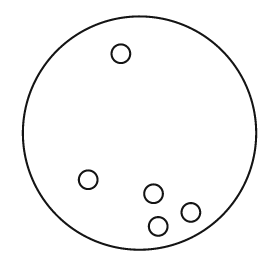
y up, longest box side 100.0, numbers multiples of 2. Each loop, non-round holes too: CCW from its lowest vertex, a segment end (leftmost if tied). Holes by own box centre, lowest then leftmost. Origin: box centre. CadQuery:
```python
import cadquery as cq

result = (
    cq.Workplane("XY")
    .moveTo(0.0, 0.0)
    .circle(50.0)
    .moveTo(8.0, -40.0)
    .circle(4.0)
    .moveTo(22.0, -34.0)
    .circle(4.0)
    .moveTo(6.0, -26.0)
    .circle(4.0)
    .moveTo(-22.0, -20.0)
    .circle(4.0)
    .moveTo(-8.0, 34.0)
    .circle(4.0)
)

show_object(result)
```